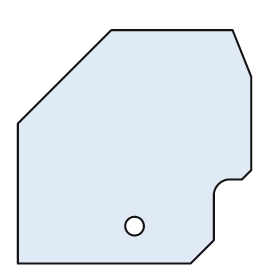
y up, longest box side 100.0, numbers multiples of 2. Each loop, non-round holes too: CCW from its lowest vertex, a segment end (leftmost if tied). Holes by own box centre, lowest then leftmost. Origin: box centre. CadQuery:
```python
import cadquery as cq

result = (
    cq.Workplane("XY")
    .moveTo(-50.0, -50.0)
    .lineTo(24.0, -50.0)
    .lineTo(34.0, -40.0)
    .lineTo(34.0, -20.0)
    .threePointArc((36.0, -16.0), (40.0, -14.0))
    .lineTo(46.0, -14.0)
    .lineTo(50.0, -10.0)
    .lineTo(50.0, 30.0)
    .lineTo(42.0, 50.0)
    .lineTo(-10.0, 50.0)
    .lineTo(-50.0, 10.0)
    .close()
    .moveTo(0.0, -34.0)
    .circle(4.0)
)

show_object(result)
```